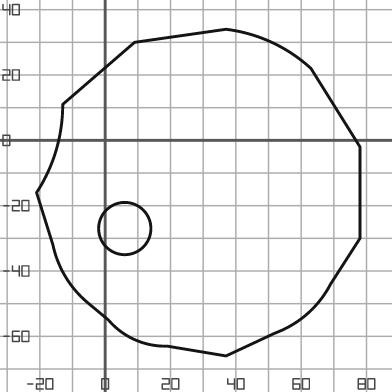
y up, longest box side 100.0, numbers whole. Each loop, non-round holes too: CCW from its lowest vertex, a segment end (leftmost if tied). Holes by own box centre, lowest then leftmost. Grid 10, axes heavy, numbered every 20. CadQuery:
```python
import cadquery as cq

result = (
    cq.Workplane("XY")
    .moveTo(37.0, -66.0)
    .lineTo(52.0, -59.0)
    .threePointArc((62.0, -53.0), (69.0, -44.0))
    .lineTo(78.0, -30.0)
    .lineTo(78.0, -2.0)
    .lineTo(63.0, 22.0)
    .threePointArc((51.0, 30.0), (37.0, 34.0))
    .lineTo(9.0, 30.0)
    .lineTo(-13.0, 11.0)
    .threePointArc((-15.0, -3.0), (-21.0, -16.0))
    .lineTo(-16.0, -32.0)
    .threePointArc((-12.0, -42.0), (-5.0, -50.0))
    .lineTo(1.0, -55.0)
    .threePointArc((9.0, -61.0), (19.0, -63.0))
    .close()
    .moveTo(6.0, -27.0)
    .circle(8.0)
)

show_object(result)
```